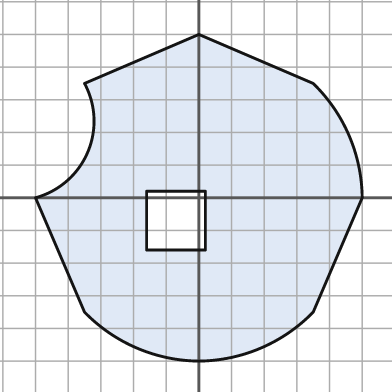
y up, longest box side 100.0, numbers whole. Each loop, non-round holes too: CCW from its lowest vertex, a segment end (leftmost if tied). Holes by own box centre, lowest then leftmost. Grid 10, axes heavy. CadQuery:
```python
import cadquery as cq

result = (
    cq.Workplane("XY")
    .moveTo(0.0, -50.0)
    .threePointArc((19.0, -46.0), (35.0, -35.0))
    .lineTo(50.0, 0.0)
    .threePointArc((46.0, 19.0), (35.0, 35.0))
    .lineTo(0.0, 50.0)
    .lineTo(-35.0, 35.0)
    .threePointArc((-34.0, 14.0), (-50.0, 0.0))
    .lineTo(-35.0, -35.0)
    .threePointArc((-19.0, -46.0), (0.0, -50.0))
    .close()
    .moveTo(-16.0, -16.0)
    .lineTo(2.0, -16.0)
    .lineTo(2.0, 2.0)
    .lineTo(-16.0, 2.0)
    .close()
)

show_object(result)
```